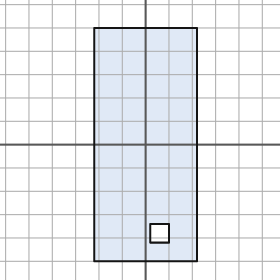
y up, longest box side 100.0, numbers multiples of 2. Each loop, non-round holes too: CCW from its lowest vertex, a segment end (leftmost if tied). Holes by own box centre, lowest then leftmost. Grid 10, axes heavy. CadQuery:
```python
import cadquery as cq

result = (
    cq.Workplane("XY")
    .moveTo(-22.0, -50.0)
    .lineTo(22.0, -50.0)
    .lineTo(22.0, 50.0)
    .lineTo(-22.0, 50.0)
    .close()
    .moveTo(2.0, -42.0)
    .lineTo(10.0, -42.0)
    .lineTo(10.0, -34.0)
    .lineTo(2.0, -34.0)
    .close()
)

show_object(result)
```